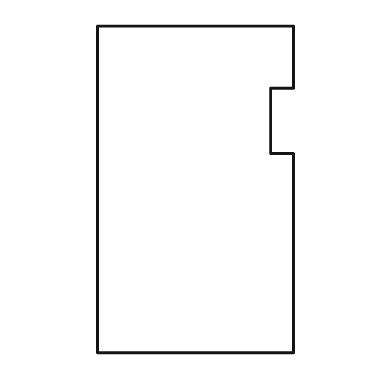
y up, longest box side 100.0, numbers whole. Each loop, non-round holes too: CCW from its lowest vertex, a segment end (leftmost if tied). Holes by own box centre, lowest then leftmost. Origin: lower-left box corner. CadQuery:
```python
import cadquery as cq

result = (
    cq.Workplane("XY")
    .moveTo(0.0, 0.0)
    .lineTo(60.0, 0.0)
    .lineTo(60.0, 61.0)
    .lineTo(53.0, 61.0)
    .lineTo(53.0, 81.0)
    .lineTo(60.0, 81.0)
    .lineTo(60.0, 100.0)
    .lineTo(0.0, 100.0)
    .close()
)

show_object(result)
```